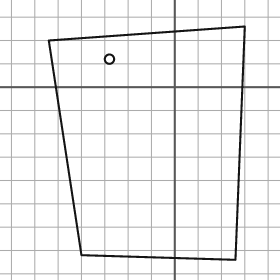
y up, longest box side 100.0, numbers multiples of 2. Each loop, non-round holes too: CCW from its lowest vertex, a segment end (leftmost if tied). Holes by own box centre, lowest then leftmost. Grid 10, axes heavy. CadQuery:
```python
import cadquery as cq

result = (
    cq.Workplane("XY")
    .moveTo(26.0, -74.0)
    .lineTo(30.0, 26.0)
    .lineTo(-54.0, 20.0)
    .lineTo(-40.0, -72.0)
    .close()
    .moveTo(-28.0, 12.0)
    .circle(2.0)
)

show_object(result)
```